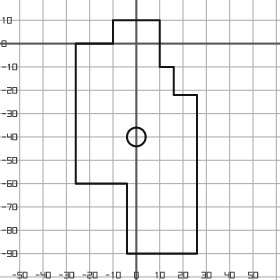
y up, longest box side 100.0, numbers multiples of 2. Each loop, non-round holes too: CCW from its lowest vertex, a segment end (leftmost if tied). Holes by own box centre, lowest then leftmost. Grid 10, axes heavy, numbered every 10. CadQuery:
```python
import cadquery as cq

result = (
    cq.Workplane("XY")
    .moveTo(-4.0, -90.0)
    .lineTo(26.0, -90.0)
    .lineTo(26.0, -22.0)
    .lineTo(16.0, -22.0)
    .lineTo(16.0, -10.0)
    .lineTo(10.0, -10.0)
    .lineTo(10.0, 10.0)
    .lineTo(-10.0, 10.0)
    .lineTo(-10.0, 0.0)
    .lineTo(-26.0, 0.0)
    .lineTo(-26.0, -60.0)
    .lineTo(-4.0, -60.0)
    .close()
    .moveTo(0.0, -40.0)
    .circle(4.0)
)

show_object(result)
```